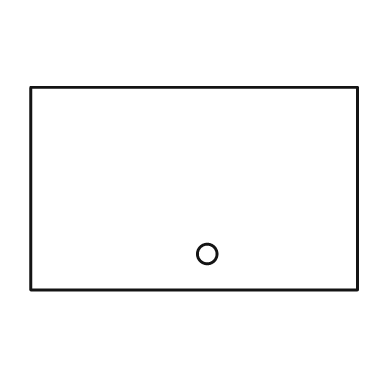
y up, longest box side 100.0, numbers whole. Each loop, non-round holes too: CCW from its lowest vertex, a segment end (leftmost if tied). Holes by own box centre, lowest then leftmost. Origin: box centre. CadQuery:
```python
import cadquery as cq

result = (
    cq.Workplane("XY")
    .moveTo(-50.0, -31.0)
    .lineTo(50.0, -31.0)
    .lineTo(50.0, 31.0)
    .lineTo(-50.0, 31.0)
    .close()
    .moveTo(4.0, -20.0)
    .circle(3.0)
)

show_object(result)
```